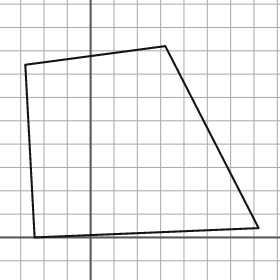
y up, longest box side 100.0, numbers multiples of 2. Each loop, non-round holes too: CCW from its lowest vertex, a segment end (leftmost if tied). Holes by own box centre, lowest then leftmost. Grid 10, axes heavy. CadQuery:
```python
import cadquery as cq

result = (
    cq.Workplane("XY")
    .moveTo(-24.0, 0.0)
    .lineTo(72.0, 4.0)
    .lineTo(32.0, 82.0)
    .lineTo(-28.0, 74.0)
    .close()
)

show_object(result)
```